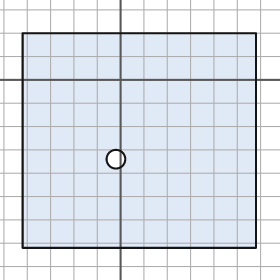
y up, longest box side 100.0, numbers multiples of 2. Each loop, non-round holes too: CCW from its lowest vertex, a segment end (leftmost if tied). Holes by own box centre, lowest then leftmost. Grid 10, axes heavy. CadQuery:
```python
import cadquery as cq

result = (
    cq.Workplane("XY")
    .moveTo(-42.0, -72.0)
    .lineTo(58.0, -72.0)
    .lineTo(58.0, 20.0)
    .lineTo(-42.0, 20.0)
    .close()
    .moveTo(-2.0, -34.0)
    .circle(4.0)
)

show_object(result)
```